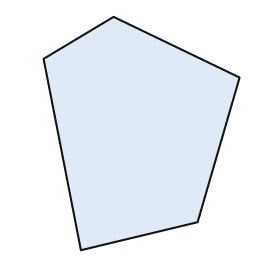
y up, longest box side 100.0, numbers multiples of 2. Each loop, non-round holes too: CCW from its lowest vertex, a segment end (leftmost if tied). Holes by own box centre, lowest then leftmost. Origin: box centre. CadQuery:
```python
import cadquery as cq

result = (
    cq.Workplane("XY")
    .moveTo(-26.0, -50.0)
    .lineTo(24.0, -38.0)
    .lineTo(42.0, 24.0)
    .lineTo(-12.0, 50.0)
    .lineTo(-42.0, 32.0)
    .close()
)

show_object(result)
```